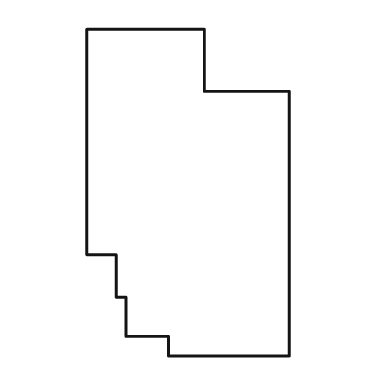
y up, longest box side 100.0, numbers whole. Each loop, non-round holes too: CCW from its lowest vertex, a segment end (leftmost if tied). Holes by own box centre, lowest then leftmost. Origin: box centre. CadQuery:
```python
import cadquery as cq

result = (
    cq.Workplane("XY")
    .moveTo(-6.0, -50.0)
    .lineTo(31.0, -50.0)
    .lineTo(31.0, 31.0)
    .lineTo(5.0, 31.0)
    .lineTo(5.0, 50.0)
    .lineTo(-31.0, 50.0)
    .lineTo(-31.0, -19.0)
    .lineTo(-22.0, -19.0)
    .lineTo(-22.0, -32.0)
    .lineTo(-19.0, -32.0)
    .lineTo(-19.0, -44.0)
    .lineTo(-6.0, -44.0)
    .close()
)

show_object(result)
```